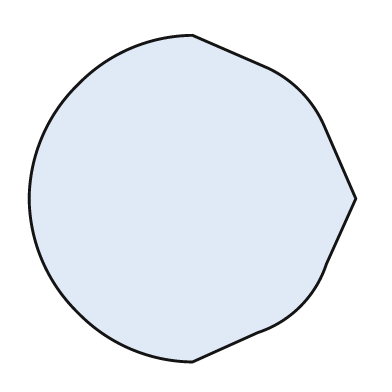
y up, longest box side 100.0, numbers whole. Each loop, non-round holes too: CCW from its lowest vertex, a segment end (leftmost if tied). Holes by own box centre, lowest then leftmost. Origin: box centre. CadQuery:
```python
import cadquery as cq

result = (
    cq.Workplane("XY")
    .moveTo(0.0, -50.0)
    .lineTo(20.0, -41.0)
    .threePointArc((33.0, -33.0), (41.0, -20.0))
    .lineTo(50.0, 0.0)
    .lineTo(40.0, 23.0)
    .threePointArc((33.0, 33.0), (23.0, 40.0))
    .lineTo(0.0, 50.0)
    .threePointArc((-19.0, 46.0), (-35.0, 35.0))
    .threePointArc((-46.0, 19.0), (-50.0, 0.0))
    .threePointArc((-46.0, -19.0), (-35.0, -35.0))
    .threePointArc((-19.0, -46.0), (0.0, -50.0))
    .close()
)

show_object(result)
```